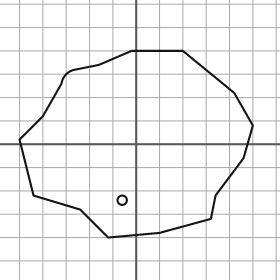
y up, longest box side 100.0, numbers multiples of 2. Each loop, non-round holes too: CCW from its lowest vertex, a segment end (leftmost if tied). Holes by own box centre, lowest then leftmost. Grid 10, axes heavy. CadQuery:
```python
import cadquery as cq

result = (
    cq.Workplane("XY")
    .moveTo(-12.0, -40.0)
    .lineTo(10.0, -38.0)
    .lineTo(32.0, -32.0)
    .lineTo(34.0, -22.0)
    .lineTo(46.0, -6.0)
    .lineTo(50.0, 8.0)
    .lineTo(42.0, 22.0)
    .lineTo(20.0, 40.0)
    .lineTo(-2.0, 40.0)
    .lineTo(-16.0, 34.0)
    .lineTo(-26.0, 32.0)
    .threePointArc((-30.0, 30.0), (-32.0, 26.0))
    .lineTo(-40.0, 12.0)
    .lineTo(-50.0, 2.0)
    .lineTo(-44.0, -22.0)
    .lineTo(-24.0, -28.0)
    .close()
    .moveTo(-6.0, -24.0)
    .circle(2.0)
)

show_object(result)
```